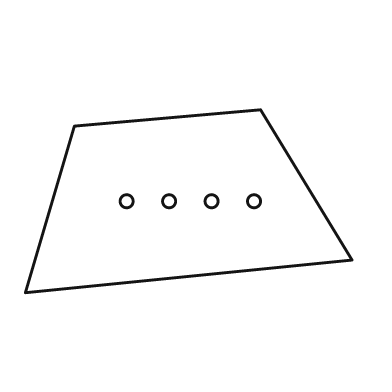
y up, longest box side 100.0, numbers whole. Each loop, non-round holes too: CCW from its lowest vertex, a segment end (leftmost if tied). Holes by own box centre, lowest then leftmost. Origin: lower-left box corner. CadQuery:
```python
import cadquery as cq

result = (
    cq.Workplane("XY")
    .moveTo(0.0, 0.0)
    .lineTo(100.0, 10.0)
    .lineTo(72.0, 56.0)
    .lineTo(15.0, 51.0)
    .close()
    .moveTo(31.0, 28.0)
    .circle(2.0)
    .moveTo(44.0, 28.0)
    .circle(2.0)
    .moveTo(57.0, 28.0)
    .circle(2.0)
    .moveTo(70.0, 28.0)
    .circle(2.0)
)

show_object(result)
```